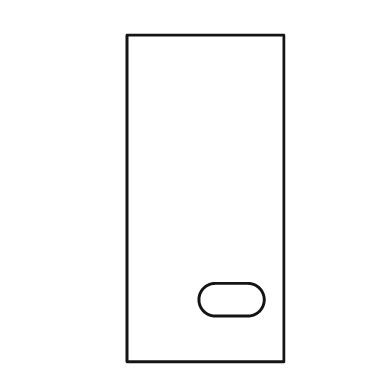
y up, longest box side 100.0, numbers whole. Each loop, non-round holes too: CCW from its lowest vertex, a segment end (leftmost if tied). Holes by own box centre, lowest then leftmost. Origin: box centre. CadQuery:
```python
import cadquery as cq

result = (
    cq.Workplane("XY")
    .moveTo(-24.0, -50.0)
    .lineTo(24.0, -50.0)
    .lineTo(24.0, 50.0)
    .lineTo(-24.0, 50.0)
    .close()
    .moveTo(3.0, -36.0)
    .lineTo(13.0, -36.0)
    .threePointArc((18.0, -31.0), (13.0, -26.0))
    .lineTo(3.0, -26.0)
    .threePointArc((-2.0, -31.0), (3.0, -36.0))
    .close()
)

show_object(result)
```